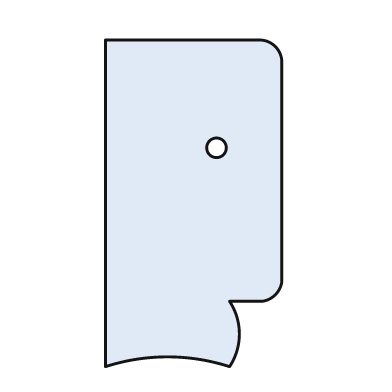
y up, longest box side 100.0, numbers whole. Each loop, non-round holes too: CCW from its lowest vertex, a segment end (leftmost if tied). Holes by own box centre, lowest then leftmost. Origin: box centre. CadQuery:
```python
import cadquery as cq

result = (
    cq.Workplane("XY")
    .moveTo(-27.0, -50.0)
    .threePointArc((-8.0, -47.0), (11.0, -50.0))
    .threePointArc((14.0, -40.0), (11.0, -30.0))
    .lineTo(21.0, -30.0)
    .threePointArc((25.0, -28.0), (27.0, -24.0))
    .lineTo(27.0, 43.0)
    .threePointArc((25.0, 48.0), (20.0, 50.0))
    .lineTo(-27.0, 50.0)
    .close()
    .moveTo(7.0, 17.0)
    .circle(3.0)
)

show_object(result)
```